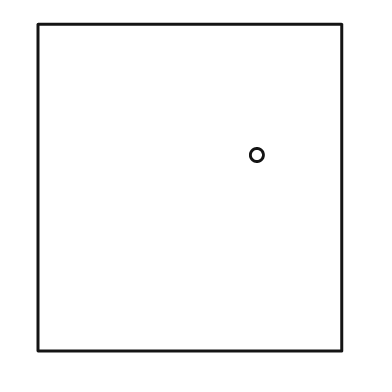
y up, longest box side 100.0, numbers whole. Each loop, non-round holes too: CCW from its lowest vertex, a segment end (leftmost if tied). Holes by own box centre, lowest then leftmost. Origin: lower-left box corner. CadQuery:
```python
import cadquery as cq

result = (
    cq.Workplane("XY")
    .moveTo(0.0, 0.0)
    .lineTo(93.0, 0.0)
    .lineTo(93.0, 100.0)
    .lineTo(0.0, 100.0)
    .close()
    .moveTo(67.0, 60.0)
    .circle(2.0)
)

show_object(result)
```